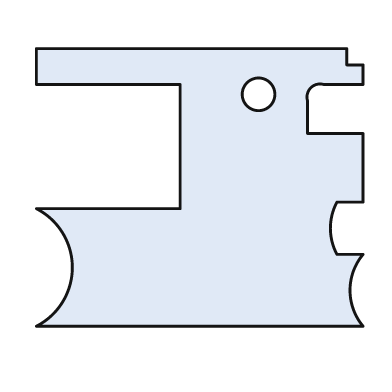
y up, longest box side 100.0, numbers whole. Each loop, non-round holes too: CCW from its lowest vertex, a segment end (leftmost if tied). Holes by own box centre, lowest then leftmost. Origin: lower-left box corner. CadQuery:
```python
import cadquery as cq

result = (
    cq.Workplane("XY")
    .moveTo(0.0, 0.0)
    .lineTo(100.0, 0.0)
    .threePointArc((96.0, 11.0), (100.0, 22.0))
    .lineTo(92.0, 22.0)
    .threePointArc((90.0, 30.0), (92.0, 38.0))
    .lineTo(100.0, 38.0)
    .lineTo(100.0, 59.0)
    .lineTo(83.0, 59.0)
    .lineTo(83.0, 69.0)
    .threePointArc((84.0, 73.0), (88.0, 74.0))
    .lineTo(100.0, 74.0)
    .lineTo(100.0, 80.0)
    .lineTo(95.0, 80.0)
    .lineTo(95.0, 85.0)
    .lineTo(0.0, 85.0)
    .lineTo(0.0, 74.0)
    .lineTo(44.0, 74.0)
    .lineTo(44.0, 36.0)
    .lineTo(0.0, 36.0)
    .threePointArc((11.0, 18.0), (0.0, 0.0))
    .close()
    .moveTo(68.0, 71.0)
    .circle(5.0)
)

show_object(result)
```